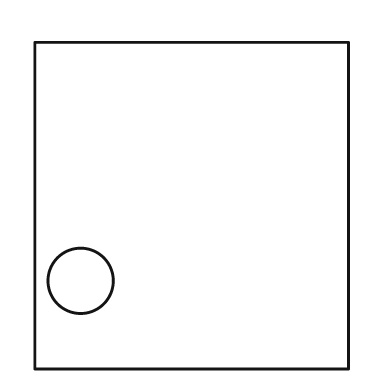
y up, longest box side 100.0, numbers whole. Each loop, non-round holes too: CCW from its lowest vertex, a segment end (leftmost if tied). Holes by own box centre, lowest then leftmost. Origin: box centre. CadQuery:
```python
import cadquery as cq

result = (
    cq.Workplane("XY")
    .moveTo(-48.0, -50.0)
    .lineTo(48.0, -50.0)
    .lineTo(48.0, 50.0)
    .lineTo(-48.0, 50.0)
    .close()
    .moveTo(-34.0, -23.0)
    .circle(10.0)
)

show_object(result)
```